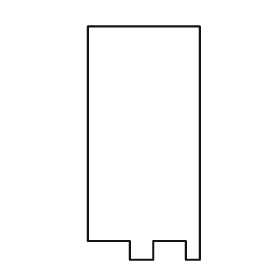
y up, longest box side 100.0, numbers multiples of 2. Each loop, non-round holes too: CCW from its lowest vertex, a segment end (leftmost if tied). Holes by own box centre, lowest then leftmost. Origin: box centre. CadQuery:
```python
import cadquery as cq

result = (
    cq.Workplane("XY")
    .moveTo(-6.0, -50.0)
    .lineTo(4.0, -50.0)
    .lineTo(4.0, -42.0)
    .lineTo(18.0, -42.0)
    .lineTo(18.0, -50.0)
    .lineTo(24.0, -50.0)
    .lineTo(24.0, 50.0)
    .lineTo(-24.0, 50.0)
    .lineTo(-24.0, -42.0)
    .lineTo(-6.0, -42.0)
    .close()
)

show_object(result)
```